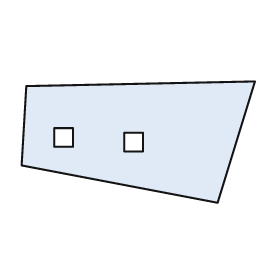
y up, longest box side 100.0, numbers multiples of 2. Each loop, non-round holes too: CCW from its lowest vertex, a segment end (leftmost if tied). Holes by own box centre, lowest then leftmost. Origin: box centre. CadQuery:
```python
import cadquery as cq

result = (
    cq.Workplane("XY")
    .moveTo(34.0, -26.0)
    .lineTo(50.0, 26.0)
    .lineTo(-48.0, 24.0)
    .lineTo(-50.0, -10.0)
    .close()
    .moveTo(-6.0, -4.0)
    .lineTo(2.0, -4.0)
    .lineTo(2.0, 4.0)
    .lineTo(-6.0, 4.0)
    .close()
    .moveTo(-36.0, -2.0)
    .lineTo(-28.0, -2.0)
    .lineTo(-28.0, 6.0)
    .lineTo(-36.0, 6.0)
    .close()
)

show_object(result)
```